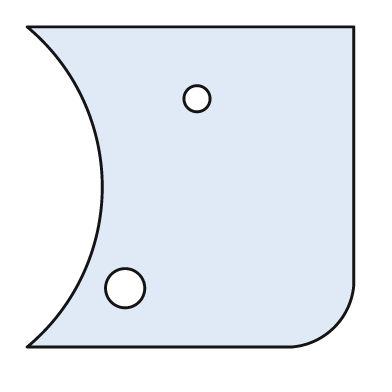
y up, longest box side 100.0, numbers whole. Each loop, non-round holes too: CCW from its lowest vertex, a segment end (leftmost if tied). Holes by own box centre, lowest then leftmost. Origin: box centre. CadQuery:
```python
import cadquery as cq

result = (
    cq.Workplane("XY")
    .moveTo(-50.0, -49.0)
    .lineTo(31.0, -49.0)
    .threePointArc((44.0, -43.0), (50.0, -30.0))
    .lineTo(50.0, 49.0)
    .lineTo(-50.0, 49.0)
    .threePointArc((-27.0, 0.0), (-50.0, -49.0))
    .close()
    .moveTo(-20.0, -31.0)
    .circle(6.0)
    .moveTo(2.0, 27.0)
    .circle(4.0)
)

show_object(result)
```